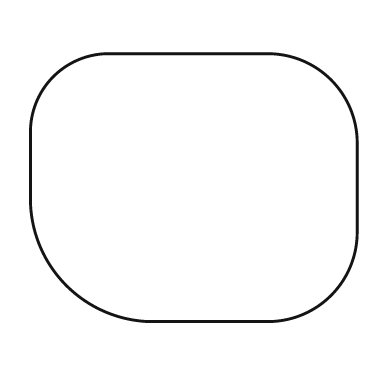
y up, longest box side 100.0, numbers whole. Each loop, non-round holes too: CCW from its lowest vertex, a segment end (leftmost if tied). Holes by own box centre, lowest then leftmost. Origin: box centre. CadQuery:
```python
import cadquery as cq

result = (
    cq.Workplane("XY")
    .moveTo(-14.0, -41.0)
    .lineTo(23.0, -41.0)
    .threePointArc((42.0, -33.0), (50.0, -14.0))
    .lineTo(50.0, 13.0)
    .threePointArc((42.0, 33.0), (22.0, 41.0))
    .lineTo(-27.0, 41.0)
    .threePointArc((-43.0, 34.0), (-50.0, 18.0))
    .lineTo(-50.0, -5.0)
    .threePointArc((-39.0, -30.0), (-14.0, -41.0))
    .close()
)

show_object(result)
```